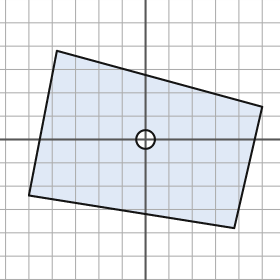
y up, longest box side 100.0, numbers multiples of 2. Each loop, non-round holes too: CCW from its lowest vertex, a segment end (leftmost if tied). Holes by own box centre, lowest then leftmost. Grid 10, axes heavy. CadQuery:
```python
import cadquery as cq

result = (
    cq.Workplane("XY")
    .moveTo(38.0, -38.0)
    .lineTo(50.0, 14.0)
    .lineTo(-38.0, 38.0)
    .lineTo(-50.0, -24.0)
    .close()
    .moveTo(0.0, 0.0)
    .circle(4.0)
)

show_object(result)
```